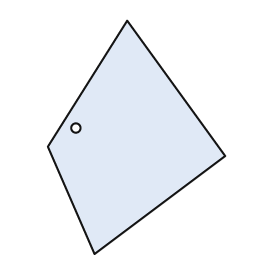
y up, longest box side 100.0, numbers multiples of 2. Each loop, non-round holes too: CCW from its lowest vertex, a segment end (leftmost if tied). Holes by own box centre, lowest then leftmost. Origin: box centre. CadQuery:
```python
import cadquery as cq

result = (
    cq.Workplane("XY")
    .moveTo(-18.0, -50.0)
    .lineTo(38.0, -8.0)
    .lineTo(-4.0, 50.0)
    .lineTo(-38.0, -4.0)
    .close()
    .moveTo(-26.0, 4.0)
    .circle(2.0)
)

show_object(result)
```